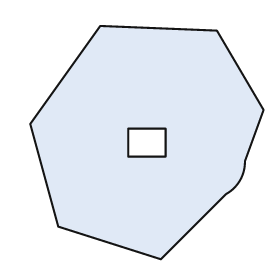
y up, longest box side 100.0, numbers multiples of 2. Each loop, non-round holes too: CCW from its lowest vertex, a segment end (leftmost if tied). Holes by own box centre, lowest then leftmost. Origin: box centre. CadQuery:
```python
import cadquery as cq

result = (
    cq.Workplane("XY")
    .moveTo(6.0, -50.0)
    .lineTo(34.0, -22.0)
    .threePointArc((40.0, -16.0), (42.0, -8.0))
    .lineTo(50.0, 14.0)
    .lineTo(30.0, 48.0)
    .lineTo(-20.0, 50.0)
    .lineTo(-50.0, 8.0)
    .lineTo(-38.0, -36.0)
    .close()
    .moveTo(-8.0, -6.0)
    .lineTo(8.0, -6.0)
    .lineTo(8.0, 6.0)
    .lineTo(-8.0, 6.0)
    .close()
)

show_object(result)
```